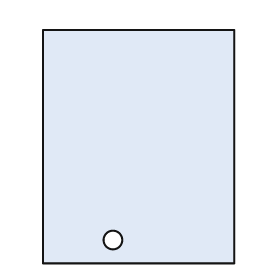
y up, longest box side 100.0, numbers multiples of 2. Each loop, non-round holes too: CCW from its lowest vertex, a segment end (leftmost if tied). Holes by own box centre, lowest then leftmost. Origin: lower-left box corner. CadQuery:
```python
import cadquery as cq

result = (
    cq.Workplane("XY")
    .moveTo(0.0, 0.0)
    .lineTo(82.0, 0.0)
    .lineTo(82.0, 100.0)
    .lineTo(0.0, 100.0)
    .close()
    .moveTo(30.0, 10.0)
    .circle(4.0)
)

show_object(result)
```